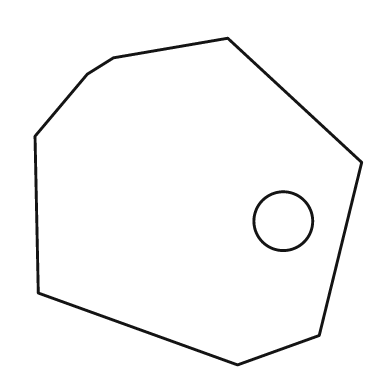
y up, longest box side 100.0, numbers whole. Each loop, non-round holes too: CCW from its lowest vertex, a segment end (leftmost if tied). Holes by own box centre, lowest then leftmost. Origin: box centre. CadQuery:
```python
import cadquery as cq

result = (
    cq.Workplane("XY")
    .moveTo(12.0, -50.0)
    .lineTo(37.0, -41.0)
    .lineTo(50.0, 12.0)
    .lineTo(9.0, 50.0)
    .lineTo(-26.0, 44.0)
    .lineTo(-34.0, 39.0)
    .lineTo(-50.0, 20.0)
    .lineTo(-49.0, -28.0)
    .close()
    .moveTo(26.0, -6.0)
    .circle(9.0)
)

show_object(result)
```